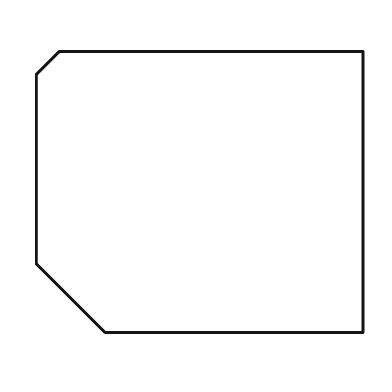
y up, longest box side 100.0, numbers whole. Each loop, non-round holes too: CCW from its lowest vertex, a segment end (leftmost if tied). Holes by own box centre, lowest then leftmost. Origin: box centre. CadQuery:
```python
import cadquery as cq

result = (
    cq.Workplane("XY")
    .moveTo(-29.0, -43.0)
    .lineTo(50.0, -43.0)
    .lineTo(50.0, 43.0)
    .lineTo(-43.0, 43.0)
    .lineTo(-50.0, 36.0)
    .lineTo(-50.0, -22.0)
    .close()
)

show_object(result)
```